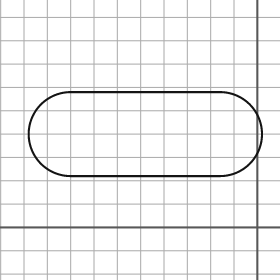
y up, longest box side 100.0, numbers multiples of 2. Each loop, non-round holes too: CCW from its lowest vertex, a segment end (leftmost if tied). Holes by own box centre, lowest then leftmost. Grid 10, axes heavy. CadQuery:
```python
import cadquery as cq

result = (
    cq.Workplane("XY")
    .moveTo(-80.0, 22.0)
    .lineTo(-16.0, 22.0)
    .threePointArc((2.0, 40.0), (-16.0, 58.0))
    .lineTo(-80.0, 58.0)
    .threePointArc((-98.0, 40.0), (-80.0, 22.0))
    .close()
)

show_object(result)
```